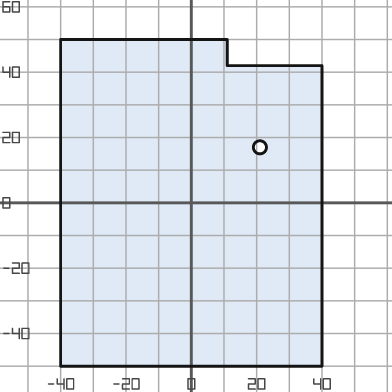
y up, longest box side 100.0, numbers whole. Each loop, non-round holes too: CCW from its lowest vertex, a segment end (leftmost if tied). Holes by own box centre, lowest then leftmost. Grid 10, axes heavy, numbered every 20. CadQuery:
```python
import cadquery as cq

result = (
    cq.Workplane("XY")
    .moveTo(-40.0, -50.0)
    .lineTo(40.0, -50.0)
    .lineTo(40.0, 42.0)
    .lineTo(11.0, 42.0)
    .lineTo(11.0, 50.0)
    .lineTo(-40.0, 50.0)
    .close()
    .moveTo(21.0, 17.0)
    .circle(2.0)
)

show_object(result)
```